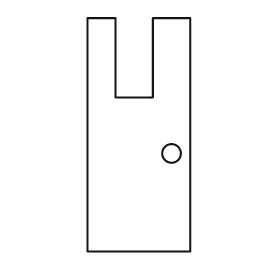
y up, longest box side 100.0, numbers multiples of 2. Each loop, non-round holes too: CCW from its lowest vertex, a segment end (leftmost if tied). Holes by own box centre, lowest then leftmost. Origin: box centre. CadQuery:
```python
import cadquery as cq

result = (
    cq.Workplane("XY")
    .moveTo(-22.0, -50.0)
    .lineTo(22.0, -50.0)
    .lineTo(22.0, 50.0)
    .lineTo(6.0, 50.0)
    .lineTo(6.0, 16.0)
    .lineTo(-10.0, 16.0)
    .lineTo(-10.0, 50.0)
    .lineTo(-22.0, 50.0)
    .close()
    .moveTo(14.0, -8.0)
    .circle(4.0)
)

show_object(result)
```